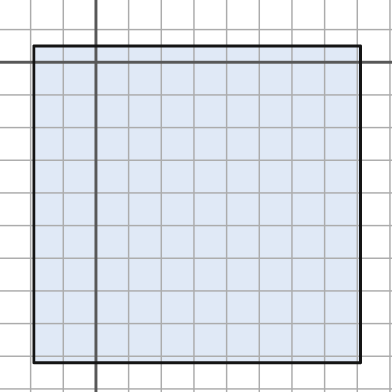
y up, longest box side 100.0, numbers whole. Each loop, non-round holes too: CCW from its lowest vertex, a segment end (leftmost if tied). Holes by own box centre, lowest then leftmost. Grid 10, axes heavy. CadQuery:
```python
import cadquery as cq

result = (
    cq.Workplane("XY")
    .moveTo(-19.0, -92.0)
    .lineTo(81.0, -92.0)
    .lineTo(81.0, 5.0)
    .lineTo(-19.0, 5.0)
    .close()
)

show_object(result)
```